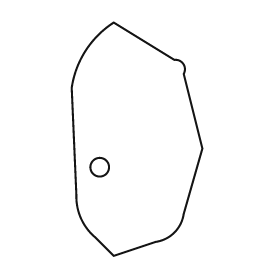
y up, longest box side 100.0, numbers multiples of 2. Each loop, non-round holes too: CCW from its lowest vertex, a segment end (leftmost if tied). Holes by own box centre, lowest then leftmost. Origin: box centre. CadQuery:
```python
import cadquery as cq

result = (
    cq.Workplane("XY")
    .moveTo(-10.0, -50.0)
    .lineTo(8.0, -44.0)
    .threePointArc((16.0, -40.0), (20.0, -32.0))
    .lineTo(28.0, -4.0)
    .lineTo(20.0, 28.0)
    .threePointArc((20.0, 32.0), (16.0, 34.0))
    .lineTo(-10.0, 50.0)
    .threePointArc((-22.0, 38.0), (-28.0, 22.0))
    .lineTo(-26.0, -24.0)
    .threePointArc((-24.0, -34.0), (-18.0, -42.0))
    .close()
    .moveTo(-16.0, -12.0)
    .circle(4.0)
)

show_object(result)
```